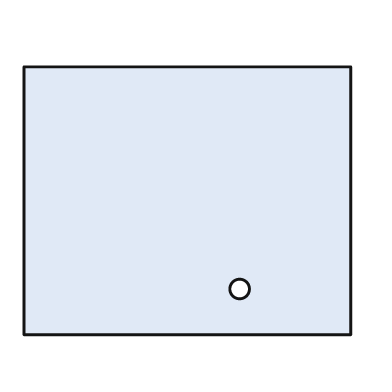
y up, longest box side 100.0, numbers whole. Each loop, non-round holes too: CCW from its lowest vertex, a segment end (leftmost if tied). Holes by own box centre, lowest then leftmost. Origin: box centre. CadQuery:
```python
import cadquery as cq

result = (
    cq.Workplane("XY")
    .moveTo(-50.0, -41.0)
    .lineTo(50.0, -41.0)
    .lineTo(50.0, 41.0)
    .lineTo(-50.0, 41.0)
    .close()
    .moveTo(16.0, -27.0)
    .circle(3.0)
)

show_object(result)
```